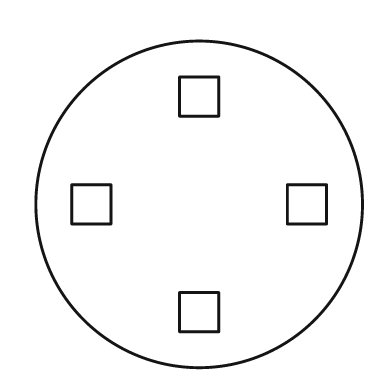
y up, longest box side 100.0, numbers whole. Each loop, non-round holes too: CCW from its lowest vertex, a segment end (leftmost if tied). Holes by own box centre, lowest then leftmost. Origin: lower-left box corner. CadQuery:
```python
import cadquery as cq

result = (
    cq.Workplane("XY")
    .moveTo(50.0, 50.0)
    .circle(50.0)
    .moveTo(44.0, 11.0)
    .lineTo(56.0, 11.0)
    .lineTo(56.0, 23.0)
    .lineTo(44.0, 23.0)
    .close()
    .moveTo(11.0, 44.0)
    .lineTo(23.0, 44.0)
    .lineTo(23.0, 56.0)
    .lineTo(11.0, 56.0)
    .close()
    .moveTo(77.0, 44.0)
    .lineTo(89.0, 44.0)
    .lineTo(89.0, 56.0)
    .lineTo(77.0, 56.0)
    .close()
    .moveTo(44.0, 77.0)
    .lineTo(56.0, 77.0)
    .lineTo(56.0, 89.0)
    .lineTo(44.0, 89.0)
    .close()
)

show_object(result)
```